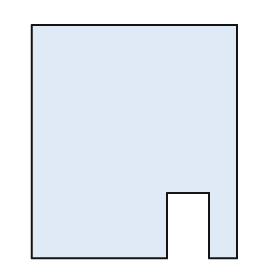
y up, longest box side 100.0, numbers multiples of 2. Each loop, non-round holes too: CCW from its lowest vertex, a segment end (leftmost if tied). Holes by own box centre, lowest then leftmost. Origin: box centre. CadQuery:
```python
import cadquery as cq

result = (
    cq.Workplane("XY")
    .moveTo(-44.0, -50.0)
    .lineTo(14.0, -50.0)
    .lineTo(14.0, -22.0)
    .lineTo(32.0, -22.0)
    .lineTo(32.0, -50.0)
    .lineTo(44.0, -50.0)
    .lineTo(44.0, 50.0)
    .lineTo(-44.0, 50.0)
    .close()
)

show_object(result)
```